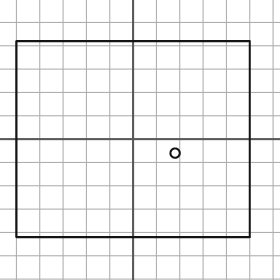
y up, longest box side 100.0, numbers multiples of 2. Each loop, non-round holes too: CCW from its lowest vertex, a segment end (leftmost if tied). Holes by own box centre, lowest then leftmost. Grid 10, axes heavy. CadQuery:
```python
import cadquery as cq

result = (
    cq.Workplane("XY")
    .moveTo(-50.0, -42.0)
    .lineTo(50.0, -42.0)
    .lineTo(50.0, 42.0)
    .lineTo(-50.0, 42.0)
    .close()
    .moveTo(18.0, -6.0)
    .circle(2.0)
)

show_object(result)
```